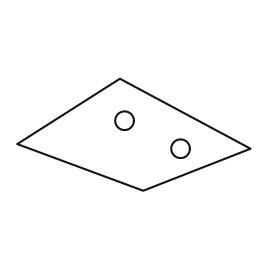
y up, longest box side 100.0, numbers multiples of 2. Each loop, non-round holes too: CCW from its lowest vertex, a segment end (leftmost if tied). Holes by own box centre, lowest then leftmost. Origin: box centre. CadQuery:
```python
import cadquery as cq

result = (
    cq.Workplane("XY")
    .moveTo(4.0, -24.0)
    .lineTo(50.0, -6.0)
    .lineTo(-6.0, 24.0)
    .lineTo(-50.0, -4.0)
    .close()
    .moveTo(20.0, -6.0)
    .circle(4.0)
    .moveTo(-4.0, 6.0)
    .circle(4.0)
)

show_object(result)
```